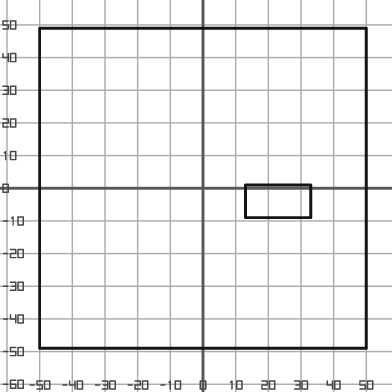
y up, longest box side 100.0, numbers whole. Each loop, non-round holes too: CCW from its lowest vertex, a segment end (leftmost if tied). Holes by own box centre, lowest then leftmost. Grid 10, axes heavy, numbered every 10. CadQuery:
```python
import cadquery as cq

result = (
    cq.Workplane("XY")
    .moveTo(-50.0, -49.0)
    .lineTo(50.0, -49.0)
    .lineTo(50.0, 49.0)
    .lineTo(-50.0, 49.0)
    .close()
    .moveTo(13.0, -9.0)
    .lineTo(33.0, -9.0)
    .lineTo(33.0, 1.0)
    .lineTo(13.0, 1.0)
    .close()
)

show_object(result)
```